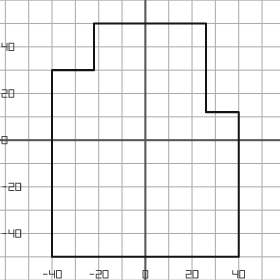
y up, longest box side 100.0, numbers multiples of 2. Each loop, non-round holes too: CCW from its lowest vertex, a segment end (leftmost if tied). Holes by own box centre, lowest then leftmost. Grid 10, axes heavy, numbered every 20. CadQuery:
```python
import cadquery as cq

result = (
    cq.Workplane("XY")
    .moveTo(-40.0, -50.0)
    .lineTo(40.0, -50.0)
    .lineTo(40.0, 12.0)
    .lineTo(26.0, 12.0)
    .lineTo(26.0, 50.0)
    .lineTo(-22.0, 50.0)
    .lineTo(-22.0, 30.0)
    .lineTo(-40.0, 30.0)
    .close()
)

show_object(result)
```